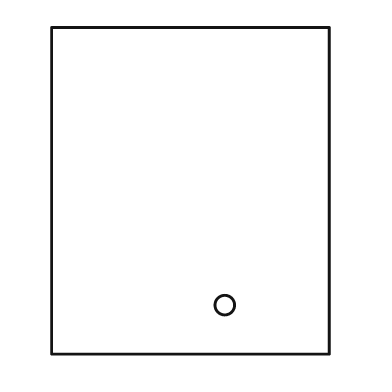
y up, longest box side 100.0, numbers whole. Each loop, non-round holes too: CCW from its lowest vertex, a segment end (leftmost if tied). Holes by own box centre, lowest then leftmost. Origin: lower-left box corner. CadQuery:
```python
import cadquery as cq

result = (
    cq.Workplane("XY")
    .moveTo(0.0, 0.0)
    .lineTo(85.0, 0.0)
    .lineTo(85.0, 100.0)
    .lineTo(0.0, 100.0)
    .close()
    .moveTo(53.0, 15.0)
    .circle(3.0)
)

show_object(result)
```